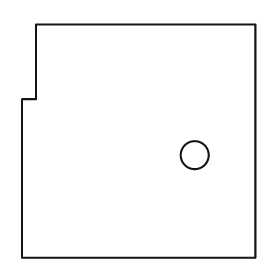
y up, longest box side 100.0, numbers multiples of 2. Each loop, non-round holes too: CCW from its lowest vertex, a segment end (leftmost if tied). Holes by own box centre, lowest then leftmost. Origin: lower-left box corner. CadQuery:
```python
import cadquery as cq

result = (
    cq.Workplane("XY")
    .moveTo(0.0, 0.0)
    .lineTo(100.0, 0.0)
    .lineTo(100.0, 100.0)
    .lineTo(6.0, 100.0)
    .lineTo(6.0, 68.0)
    .lineTo(0.0, 68.0)
    .close()
    .moveTo(74.0, 44.0)
    .circle(6.0)
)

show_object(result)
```